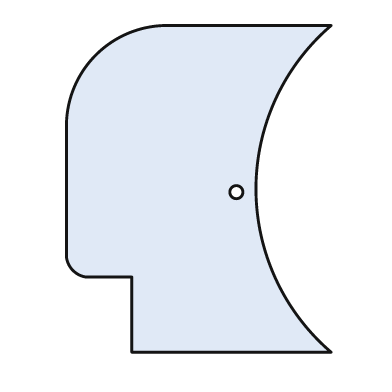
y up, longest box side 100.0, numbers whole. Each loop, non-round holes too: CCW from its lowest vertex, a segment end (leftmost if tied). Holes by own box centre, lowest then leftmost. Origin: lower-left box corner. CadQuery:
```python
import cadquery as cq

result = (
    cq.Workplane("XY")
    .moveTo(20.0, 0.0)
    .lineTo(81.0, 0.0)
    .threePointArc((58.0, 50.0), (81.0, 100.0))
    .lineTo(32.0, 100.0)
    .threePointArc((9.0, 91.0), (0.0, 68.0))
    .lineTo(0.0, 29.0)
    .threePointArc((2.0, 25.0), (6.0, 23.0))
    .lineTo(20.0, 23.0)
    .close()
    .moveTo(52.0, 49.0)
    .circle(2.0)
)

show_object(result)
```